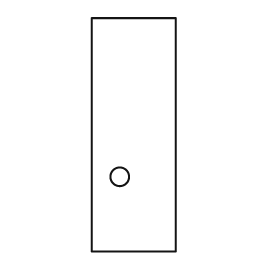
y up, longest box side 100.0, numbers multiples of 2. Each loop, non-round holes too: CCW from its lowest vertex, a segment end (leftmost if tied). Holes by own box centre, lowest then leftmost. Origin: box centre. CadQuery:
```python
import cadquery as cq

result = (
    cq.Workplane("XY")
    .moveTo(-18.0, -50.0)
    .lineTo(18.0, -50.0)
    .lineTo(18.0, 50.0)
    .lineTo(-18.0, 50.0)
    .close()
    .moveTo(-6.0, -18.0)
    .circle(4.0)
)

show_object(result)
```